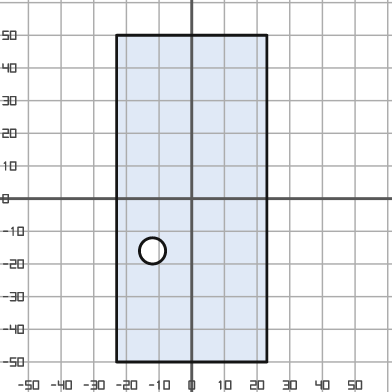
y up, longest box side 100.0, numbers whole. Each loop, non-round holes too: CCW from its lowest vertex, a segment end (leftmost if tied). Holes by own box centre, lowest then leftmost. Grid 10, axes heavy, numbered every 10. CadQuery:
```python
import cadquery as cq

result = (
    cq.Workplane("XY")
    .moveTo(-23.0, -50.0)
    .lineTo(23.0, -50.0)
    .lineTo(23.0, 50.0)
    .lineTo(-23.0, 50.0)
    .close()
    .moveTo(-12.0, -16.0)
    .circle(4.0)
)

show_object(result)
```